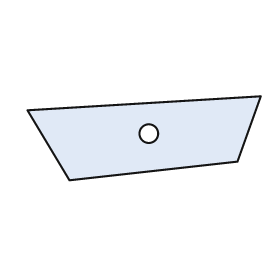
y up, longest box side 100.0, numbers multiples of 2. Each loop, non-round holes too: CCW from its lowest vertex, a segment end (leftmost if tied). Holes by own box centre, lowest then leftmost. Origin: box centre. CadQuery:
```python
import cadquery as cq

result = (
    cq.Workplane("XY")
    .moveTo(-32.0, -18.0)
    .lineTo(40.0, -10.0)
    .lineTo(50.0, 18.0)
    .lineTo(-50.0, 12.0)
    .close()
    .moveTo(2.0, 2.0)
    .circle(4.0)
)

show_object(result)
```